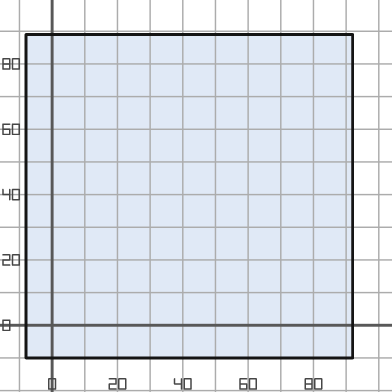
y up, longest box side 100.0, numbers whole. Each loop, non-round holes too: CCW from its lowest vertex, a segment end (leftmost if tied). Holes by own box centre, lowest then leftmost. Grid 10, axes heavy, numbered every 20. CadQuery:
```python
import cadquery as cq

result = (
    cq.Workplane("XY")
    .moveTo(-8.0, -10.0)
    .lineTo(92.0, -10.0)
    .lineTo(92.0, 89.0)
    .lineTo(-8.0, 89.0)
    .close()
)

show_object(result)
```